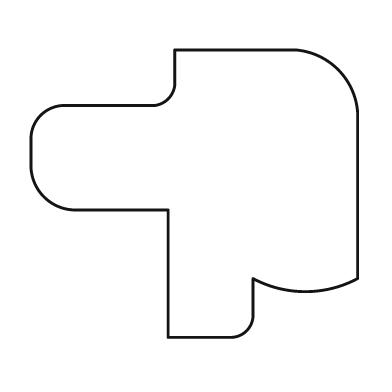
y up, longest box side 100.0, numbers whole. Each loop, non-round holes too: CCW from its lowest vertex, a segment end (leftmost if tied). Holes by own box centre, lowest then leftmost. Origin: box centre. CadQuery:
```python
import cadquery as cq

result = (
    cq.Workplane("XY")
    .moveTo(-8.0, -44.0)
    .lineTo(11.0, -44.0)
    .threePointArc((16.0, -42.0), (18.0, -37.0))
    .lineTo(18.0, -26.0)
    .threePointArc((34.0, -30.0), (50.0, -26.0))
    .lineTo(50.0, 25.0)
    .threePointArc((44.0, 38.0), (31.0, 44.0))
    .lineTo(-6.0, 44.0)
    .lineTo(-6.0, 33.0)
    .threePointArc((-8.0, 29.0), (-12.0, 27.0))
    .lineTo(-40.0, 27.0)
    .threePointArc((-47.0, 24.0), (-50.0, 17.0))
    .lineTo(-50.0, 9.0)
    .threePointArc((-46.0, -1.0), (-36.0, -5.0))
    .lineTo(-8.0, -5.0)
    .close()
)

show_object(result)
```